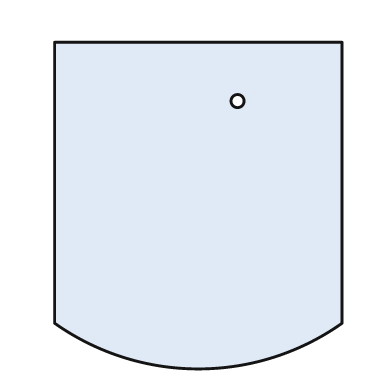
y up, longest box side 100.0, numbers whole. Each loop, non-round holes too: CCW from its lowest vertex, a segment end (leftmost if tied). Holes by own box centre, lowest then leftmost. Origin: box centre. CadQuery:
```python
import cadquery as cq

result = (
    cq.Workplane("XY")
    .moveTo(-44.0, -36.0)
    .threePointArc((0.0, -50.0), (44.0, -36.0))
    .lineTo(44.0, 50.0)
    .lineTo(-44.0, 50.0)
    .close()
    .moveTo(12.0, 32.0)
    .circle(2.0)
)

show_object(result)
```